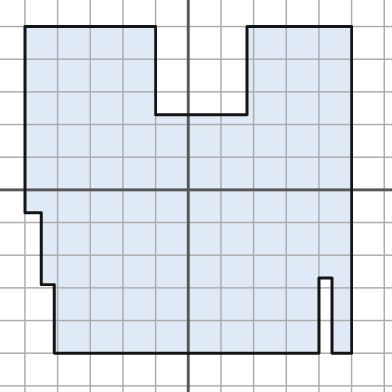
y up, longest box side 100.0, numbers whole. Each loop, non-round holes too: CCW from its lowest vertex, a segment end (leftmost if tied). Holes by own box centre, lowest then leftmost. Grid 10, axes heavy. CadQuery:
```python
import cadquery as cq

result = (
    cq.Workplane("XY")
    .moveTo(-41.0, -50.0)
    .lineTo(40.0, -50.0)
    .lineTo(40.0, -27.0)
    .lineTo(44.0, -27.0)
    .lineTo(44.0, -50.0)
    .lineTo(50.0, -50.0)
    .lineTo(50.0, 50.0)
    .lineTo(18.0, 50.0)
    .lineTo(18.0, 23.0)
    .lineTo(-10.0, 23.0)
    .lineTo(-10.0, 50.0)
    .lineTo(-50.0, 50.0)
    .lineTo(-50.0, -7.0)
    .lineTo(-45.0, -7.0)
    .lineTo(-45.0, -29.0)
    .lineTo(-41.0, -29.0)
    .close()
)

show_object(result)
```